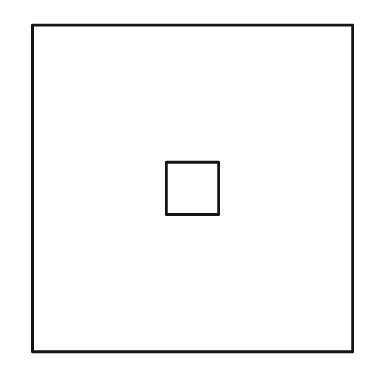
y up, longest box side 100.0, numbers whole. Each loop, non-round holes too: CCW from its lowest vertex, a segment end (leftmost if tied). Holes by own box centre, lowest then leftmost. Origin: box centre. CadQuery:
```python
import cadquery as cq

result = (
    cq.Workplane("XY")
    .moveTo(-49.0, -50.0)
    .lineTo(49.0, -50.0)
    .lineTo(49.0, 50.0)
    .lineTo(-49.0, 50.0)
    .close()
    .moveTo(-8.0, -8.0)
    .lineTo(8.0, -8.0)
    .lineTo(8.0, 8.0)
    .lineTo(-8.0, 8.0)
    .close()
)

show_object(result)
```